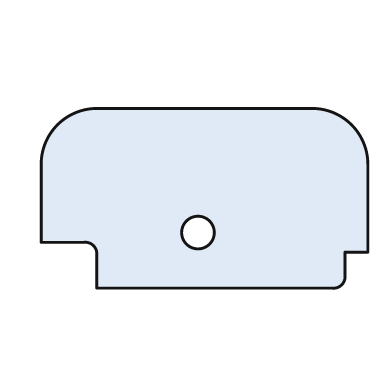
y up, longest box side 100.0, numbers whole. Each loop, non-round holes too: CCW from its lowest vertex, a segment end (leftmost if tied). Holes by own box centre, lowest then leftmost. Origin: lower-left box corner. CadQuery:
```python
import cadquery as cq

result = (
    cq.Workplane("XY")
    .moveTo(17.0, 0.0)
    .lineTo(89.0, 0.0)
    .threePointArc((92.0, 1.0), (93.0, 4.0))
    .lineTo(93.0, 11.0)
    .lineTo(100.0, 11.0)
    .lineTo(100.0, 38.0)
    .threePointArc((95.0, 50.0), (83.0, 55.0))
    .lineTo(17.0, 55.0)
    .threePointArc((5.0, 50.0), (0.0, 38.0))
    .lineTo(0.0, 14.0)
    .lineTo(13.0, 14.0)
    .threePointArc((16.0, 13.0), (17.0, 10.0))
    .close()
    .moveTo(48.0, 17.0)
    .circle(5.0)
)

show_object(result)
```